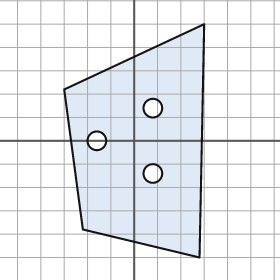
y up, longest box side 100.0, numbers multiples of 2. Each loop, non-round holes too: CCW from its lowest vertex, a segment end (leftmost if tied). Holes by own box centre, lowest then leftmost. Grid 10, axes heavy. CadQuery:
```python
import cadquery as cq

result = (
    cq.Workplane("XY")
    .moveTo(28.0, -50.0)
    .lineTo(30.0, 50.0)
    .lineTo(-30.0, 22.0)
    .lineTo(-22.0, -38.0)
    .close()
    .moveTo(8.0, -14.0)
    .circle(4.0)
    .moveTo(-16.0, 0.0)
    .circle(4.0)
    .moveTo(8.0, 14.0)
    .circle(4.0)
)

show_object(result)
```